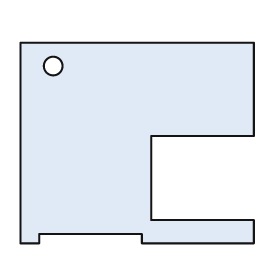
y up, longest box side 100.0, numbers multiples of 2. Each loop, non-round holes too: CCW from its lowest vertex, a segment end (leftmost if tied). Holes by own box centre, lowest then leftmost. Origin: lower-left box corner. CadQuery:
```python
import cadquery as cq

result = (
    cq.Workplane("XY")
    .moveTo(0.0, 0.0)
    .lineTo(8.0, 0.0)
    .lineTo(8.0, 4.0)
    .lineTo(52.0, 4.0)
    .lineTo(52.0, 0.0)
    .lineTo(100.0, 0.0)
    .lineTo(100.0, 10.0)
    .lineTo(56.0, 10.0)
    .lineTo(56.0, 46.0)
    .lineTo(100.0, 46.0)
    .lineTo(100.0, 86.0)
    .lineTo(0.0, 86.0)
    .close()
    .moveTo(14.0, 76.0)
    .circle(4.0)
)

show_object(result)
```